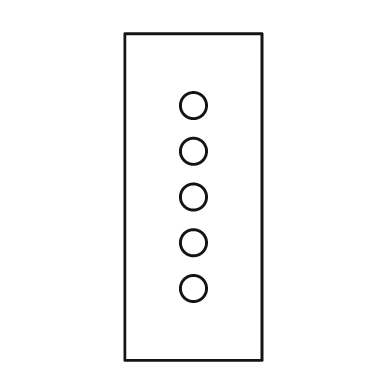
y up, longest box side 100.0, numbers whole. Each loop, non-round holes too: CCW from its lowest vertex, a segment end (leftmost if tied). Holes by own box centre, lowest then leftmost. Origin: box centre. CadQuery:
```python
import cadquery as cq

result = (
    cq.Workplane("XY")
    .moveTo(-21.0, -50.0)
    .lineTo(21.0, -50.0)
    .lineTo(21.0, 50.0)
    .lineTo(-21.0, 50.0)
    .close()
    .moveTo(0.0, -28.0)
    .circle(4.0)
    .moveTo(0.0, -14.0)
    .circle(4.0)
    .moveTo(0.0, 0.0)
    .circle(4.0)
    .moveTo(0.0, 14.0)
    .circle(4.0)
    .moveTo(0.0, 28.0)
    .circle(4.0)
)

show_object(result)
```